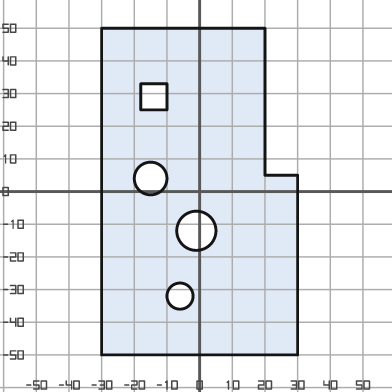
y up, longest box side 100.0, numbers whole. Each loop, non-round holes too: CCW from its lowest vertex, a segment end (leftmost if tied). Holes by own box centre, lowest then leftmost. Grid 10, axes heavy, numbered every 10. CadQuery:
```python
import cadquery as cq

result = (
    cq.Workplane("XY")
    .moveTo(-30.0, -50.0)
    .lineTo(30.0, -50.0)
    .lineTo(30.0, 5.0)
    .lineTo(20.0, 5.0)
    .lineTo(20.0, 50.0)
    .lineTo(-30.0, 50.0)
    .close()
    .moveTo(-6.0, -32.0)
    .circle(4.0)
    .moveTo(-1.0, -12.0)
    .circle(6.0)
    .moveTo(-15.0, 4.0)
    .circle(5.0)
    .moveTo(-18.0, 25.0)
    .lineTo(-10.0, 25.0)
    .lineTo(-10.0, 33.0)
    .lineTo(-18.0, 33.0)
    .close()
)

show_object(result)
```